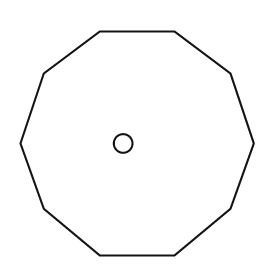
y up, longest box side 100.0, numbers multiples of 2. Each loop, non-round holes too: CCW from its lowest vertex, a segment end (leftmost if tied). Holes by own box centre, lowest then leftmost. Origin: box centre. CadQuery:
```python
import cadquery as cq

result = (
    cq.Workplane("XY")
    .moveTo(-16.0, -48.0)
    .lineTo(16.0, -48.0)
    .lineTo(40.0, -28.0)
    .lineTo(50.0, 0.0)
    .lineTo(40.0, 30.0)
    .lineTo(16.0, 48.0)
    .lineTo(-16.0, 48.0)
    .lineTo(-40.0, 30.0)
    .lineTo(-50.0, 0.0)
    .lineTo(-40.0, -28.0)
    .close()
    .moveTo(-6.0, 0.0)
    .circle(4.0)
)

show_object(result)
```